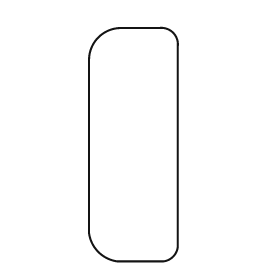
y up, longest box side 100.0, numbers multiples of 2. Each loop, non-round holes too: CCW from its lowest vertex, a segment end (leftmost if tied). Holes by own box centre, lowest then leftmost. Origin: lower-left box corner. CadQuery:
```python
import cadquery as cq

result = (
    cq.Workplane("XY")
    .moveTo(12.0, 0.0)
    .lineTo(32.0, 0.0)
    .threePointArc((36.0, 2.0), (38.0, 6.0))
    .lineTo(38.0, 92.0)
    .threePointArc((36.0, 98.0), (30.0, 100.0))
    .lineTo(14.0, 100.0)
    .threePointArc((4.0, 96.0), (0.0, 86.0))
    .lineTo(0.0, 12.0)
    .threePointArc((4.0, 4.0), (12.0, 0.0))
    .close()
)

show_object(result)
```